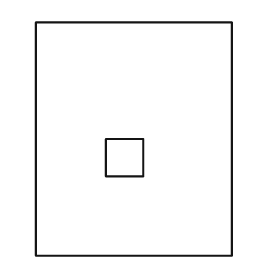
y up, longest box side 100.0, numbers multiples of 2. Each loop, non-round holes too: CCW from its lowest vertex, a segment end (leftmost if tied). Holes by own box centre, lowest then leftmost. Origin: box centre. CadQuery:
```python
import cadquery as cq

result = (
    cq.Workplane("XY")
    .moveTo(-42.0, -50.0)
    .lineTo(42.0, -50.0)
    .lineTo(42.0, 50.0)
    .lineTo(-42.0, 50.0)
    .close()
    .moveTo(-12.0, -16.0)
    .lineTo(4.0, -16.0)
    .lineTo(4.0, 0.0)
    .lineTo(-12.0, 0.0)
    .close()
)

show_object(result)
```